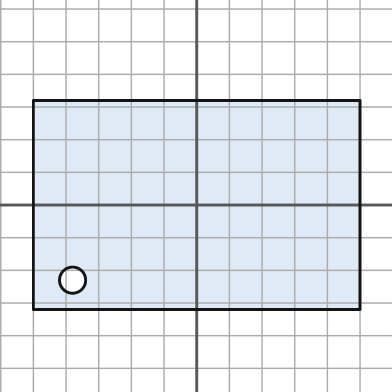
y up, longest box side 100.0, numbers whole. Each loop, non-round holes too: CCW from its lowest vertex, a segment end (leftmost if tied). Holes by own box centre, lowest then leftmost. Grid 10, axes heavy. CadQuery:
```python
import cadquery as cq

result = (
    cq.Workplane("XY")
    .moveTo(-50.0, -32.0)
    .lineTo(50.0, -32.0)
    .lineTo(50.0, 32.0)
    .lineTo(-50.0, 32.0)
    .close()
    .moveTo(-38.0, -23.0)
    .circle(4.0)
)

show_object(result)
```